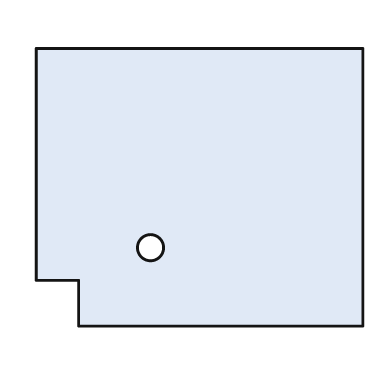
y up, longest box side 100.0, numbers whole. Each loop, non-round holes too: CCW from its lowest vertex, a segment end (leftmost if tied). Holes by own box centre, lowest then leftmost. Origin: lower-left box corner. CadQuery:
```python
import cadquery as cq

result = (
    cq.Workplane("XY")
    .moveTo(13.0, 0.0)
    .lineTo(100.0, 0.0)
    .lineTo(100.0, 85.0)
    .lineTo(0.0, 85.0)
    .lineTo(0.0, 14.0)
    .lineTo(13.0, 14.0)
    .close()
    .moveTo(35.0, 24.0)
    .circle(4.0)
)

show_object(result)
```